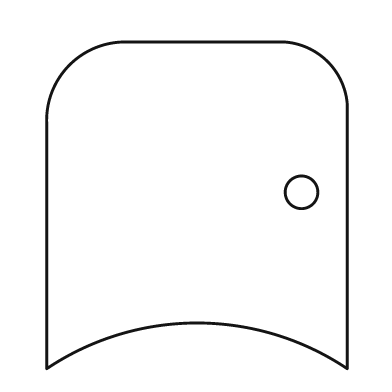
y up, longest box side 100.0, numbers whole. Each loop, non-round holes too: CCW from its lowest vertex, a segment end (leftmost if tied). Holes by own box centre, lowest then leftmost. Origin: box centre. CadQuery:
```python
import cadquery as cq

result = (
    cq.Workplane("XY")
    .moveTo(-46.0, -50.0)
    .threePointArc((0.0, -36.0), (46.0, -50.0))
    .lineTo(46.0, 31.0)
    .threePointArc((40.0, 44.0), (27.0, 50.0))
    .lineTo(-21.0, 50.0)
    .threePointArc((-39.0, 43.0), (-46.0, 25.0))
    .close()
    .moveTo(32.0, 4.0)
    .circle(5.0)
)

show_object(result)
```